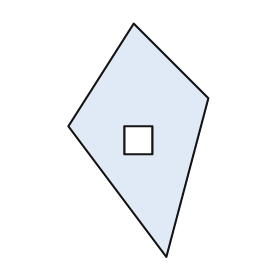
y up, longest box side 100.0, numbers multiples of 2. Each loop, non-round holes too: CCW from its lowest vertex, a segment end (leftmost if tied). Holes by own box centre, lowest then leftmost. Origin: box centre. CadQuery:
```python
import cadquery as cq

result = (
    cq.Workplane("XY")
    .moveTo(12.0, -50.0)
    .lineTo(30.0, 18.0)
    .lineTo(-2.0, 50.0)
    .lineTo(-30.0, 6.0)
    .close()
    .moveTo(-6.0, -6.0)
    .lineTo(6.0, -6.0)
    .lineTo(6.0, 6.0)
    .lineTo(-6.0, 6.0)
    .close()
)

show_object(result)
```